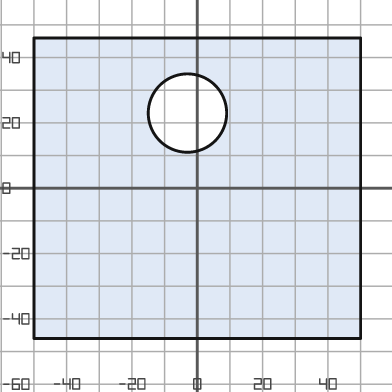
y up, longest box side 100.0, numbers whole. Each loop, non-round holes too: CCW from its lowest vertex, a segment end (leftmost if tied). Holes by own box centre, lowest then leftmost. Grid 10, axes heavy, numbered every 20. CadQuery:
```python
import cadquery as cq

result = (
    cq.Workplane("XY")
    .moveTo(-50.0, -46.0)
    .lineTo(50.0, -46.0)
    .lineTo(50.0, 46.0)
    .lineTo(-50.0, 46.0)
    .close()
    .moveTo(-3.0, 23.0)
    .circle(12.0)
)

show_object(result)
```